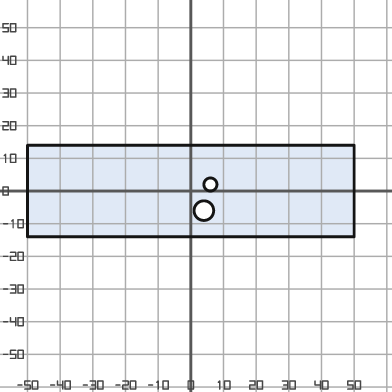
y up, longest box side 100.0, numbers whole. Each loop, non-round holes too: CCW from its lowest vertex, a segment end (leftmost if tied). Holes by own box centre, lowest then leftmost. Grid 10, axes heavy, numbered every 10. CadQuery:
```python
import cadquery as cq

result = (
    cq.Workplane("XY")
    .moveTo(-50.0, -14.0)
    .lineTo(50.0, -14.0)
    .lineTo(50.0, 14.0)
    .lineTo(-50.0, 14.0)
    .close()
    .moveTo(4.0, -6.0)
    .circle(3.0)
    .moveTo(6.0, 2.0)
    .circle(2.0)
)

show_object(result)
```